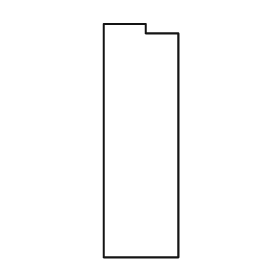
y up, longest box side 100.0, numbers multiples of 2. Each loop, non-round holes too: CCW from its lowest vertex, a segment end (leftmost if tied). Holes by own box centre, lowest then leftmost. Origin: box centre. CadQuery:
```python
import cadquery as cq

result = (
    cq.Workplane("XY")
    .moveTo(-16.0, -50.0)
    .lineTo(16.0, -50.0)
    .lineTo(16.0, 46.0)
    .lineTo(2.0, 46.0)
    .lineTo(2.0, 50.0)
    .lineTo(-16.0, 50.0)
    .close()
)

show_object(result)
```